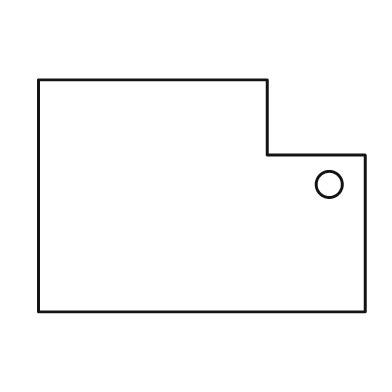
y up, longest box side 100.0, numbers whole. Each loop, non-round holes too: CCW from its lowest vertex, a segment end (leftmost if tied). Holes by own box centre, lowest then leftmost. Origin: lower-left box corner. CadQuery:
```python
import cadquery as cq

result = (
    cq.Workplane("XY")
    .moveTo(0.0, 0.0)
    .lineTo(100.0, 0.0)
    .lineTo(100.0, 48.0)
    .lineTo(70.0, 48.0)
    .lineTo(70.0, 71.0)
    .lineTo(0.0, 71.0)
    .close()
    .moveTo(89.0, 39.0)
    .circle(4.0)
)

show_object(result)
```